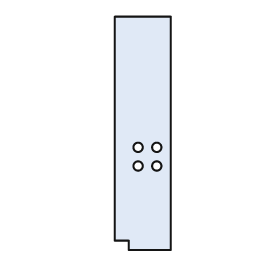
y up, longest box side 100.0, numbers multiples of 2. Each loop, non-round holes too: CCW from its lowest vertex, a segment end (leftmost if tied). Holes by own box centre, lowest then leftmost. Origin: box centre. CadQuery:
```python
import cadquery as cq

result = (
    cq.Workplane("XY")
    .moveTo(-6.0, -50.0)
    .lineTo(12.0, -50.0)
    .lineTo(12.0, 50.0)
    .lineTo(-12.0, 50.0)
    .lineTo(-12.0, -46.0)
    .lineTo(-6.0, -46.0)
    .close()
    .moveTo(-2.0, -14.0)
    .circle(2.0)
    .moveTo(6.0, -14.0)
    .circle(2.0)
    .moveTo(-2.0, -6.0)
    .circle(2.0)
    .moveTo(6.0, -6.0)
    .circle(2.0)
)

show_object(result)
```